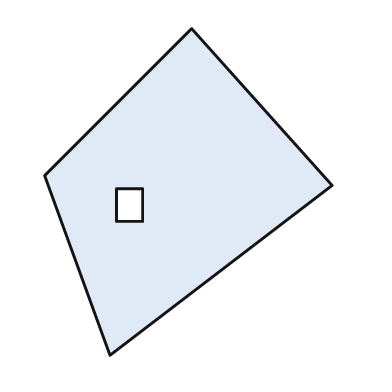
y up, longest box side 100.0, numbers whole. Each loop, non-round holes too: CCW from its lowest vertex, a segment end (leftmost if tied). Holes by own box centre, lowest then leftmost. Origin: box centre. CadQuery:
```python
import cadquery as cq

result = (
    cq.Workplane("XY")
    .moveTo(-24.0, -50.0)
    .lineTo(44.0, 2.0)
    .lineTo(1.0, 50.0)
    .lineTo(-44.0, 5.0)
    .close()
    .moveTo(-22.0, -9.0)
    .lineTo(-14.0, -9.0)
    .lineTo(-14.0, 1.0)
    .lineTo(-22.0, 1.0)
    .close()
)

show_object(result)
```